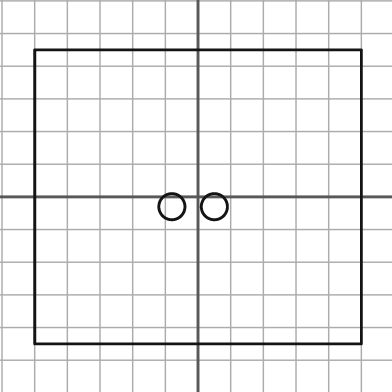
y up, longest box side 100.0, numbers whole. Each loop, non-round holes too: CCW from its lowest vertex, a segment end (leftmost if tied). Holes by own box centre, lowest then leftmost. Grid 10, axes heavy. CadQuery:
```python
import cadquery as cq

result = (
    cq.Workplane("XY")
    .moveTo(-50.0, -45.0)
    .lineTo(50.0, -45.0)
    .lineTo(50.0, 45.0)
    .lineTo(-50.0, 45.0)
    .close()
    .moveTo(-8.0, -3.0)
    .circle(4.0)
    .moveTo(5.0, -3.0)
    .circle(4.0)
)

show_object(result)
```